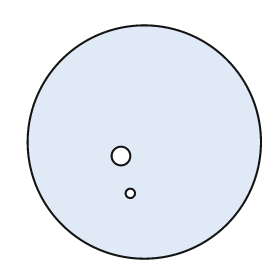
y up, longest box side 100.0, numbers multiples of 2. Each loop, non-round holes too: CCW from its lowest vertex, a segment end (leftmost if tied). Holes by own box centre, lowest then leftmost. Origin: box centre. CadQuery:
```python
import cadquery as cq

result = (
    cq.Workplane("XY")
    .moveTo(0.0, 0.0)
    .circle(50.0)
    .moveTo(-6.0, -22.0)
    .circle(2.0)
    .moveTo(-10.0, -6.0)
    .circle(4.0)
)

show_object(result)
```